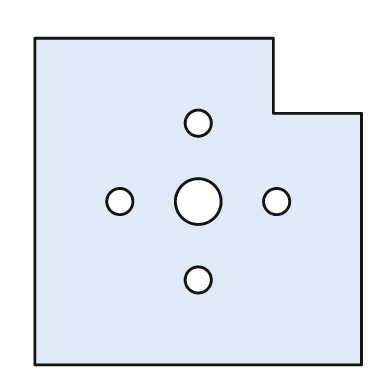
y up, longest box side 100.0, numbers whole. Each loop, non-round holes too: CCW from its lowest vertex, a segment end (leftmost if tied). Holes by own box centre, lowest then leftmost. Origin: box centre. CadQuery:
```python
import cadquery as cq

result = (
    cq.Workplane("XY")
    .moveTo(-50.0, -50.0)
    .lineTo(50.0, -50.0)
    .lineTo(50.0, 27.0)
    .lineTo(23.0, 27.0)
    .lineTo(23.0, 50.0)
    .lineTo(-50.0, 50.0)
    .close()
    .moveTo(0.0, -24.0)
    .circle(4.0)
    .moveTo(-24.0, 0.0)
    .circle(4.0)
    .moveTo(0.0, 0.0)
    .circle(7.0)
    .moveTo(24.0, 0.0)
    .circle(4.0)
    .moveTo(0.0, 24.0)
    .circle(4.0)
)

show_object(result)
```